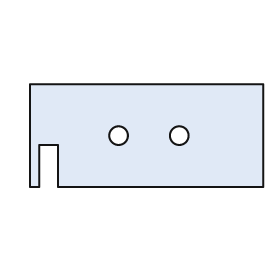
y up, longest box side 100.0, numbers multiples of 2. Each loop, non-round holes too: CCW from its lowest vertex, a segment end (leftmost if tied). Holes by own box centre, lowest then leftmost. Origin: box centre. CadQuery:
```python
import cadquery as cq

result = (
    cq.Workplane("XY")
    .moveTo(-50.0, -22.0)
    .lineTo(-46.0, -22.0)
    .lineTo(-46.0, -4.0)
    .lineTo(-38.0, -4.0)
    .lineTo(-38.0, -22.0)
    .lineTo(50.0, -22.0)
    .lineTo(50.0, 22.0)
    .lineTo(-50.0, 22.0)
    .close()
    .moveTo(-12.0, 0.0)
    .circle(4.0)
    .moveTo(14.0, 0.0)
    .circle(4.0)
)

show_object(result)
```